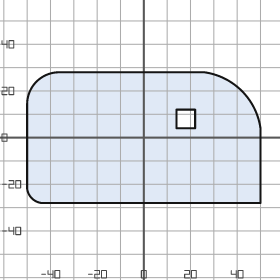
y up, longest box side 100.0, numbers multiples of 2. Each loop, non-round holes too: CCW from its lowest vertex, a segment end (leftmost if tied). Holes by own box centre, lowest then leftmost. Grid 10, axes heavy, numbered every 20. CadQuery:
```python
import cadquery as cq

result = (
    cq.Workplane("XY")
    .moveTo(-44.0, -28.0)
    .lineTo(50.0, -28.0)
    .lineTo(50.0, 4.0)
    .threePointArc((42.0, 20.0), (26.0, 28.0))
    .lineTo(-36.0, 28.0)
    .threePointArc((-46.0, 24.0), (-50.0, 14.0))
    .lineTo(-50.0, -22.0)
    .threePointArc((-48.0, -26.0), (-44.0, -28.0))
    .close()
    .moveTo(14.0, 4.0)
    .lineTo(22.0, 4.0)
    .lineTo(22.0, 12.0)
    .lineTo(14.0, 12.0)
    .close()
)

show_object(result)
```